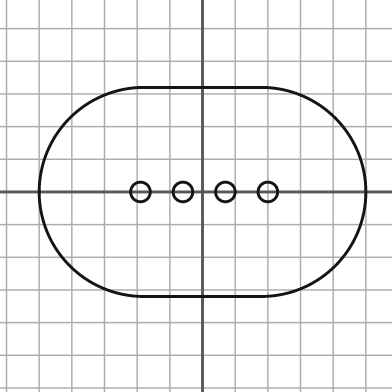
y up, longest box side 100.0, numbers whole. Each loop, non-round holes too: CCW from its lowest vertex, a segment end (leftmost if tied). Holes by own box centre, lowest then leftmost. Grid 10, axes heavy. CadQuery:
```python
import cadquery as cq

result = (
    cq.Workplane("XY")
    .moveTo(-18.0, -32.0)
    .lineTo(18.0, -32.0)
    .threePointArc((50.0, 0.0), (18.0, 32.0))
    .lineTo(-18.0, 32.0)
    .threePointArc((-50.0, 0.0), (-18.0, -32.0))
    .close()
    .moveTo(-19.0, 0.0)
    .circle(3.0)
    .moveTo(-6.0, 0.0)
    .circle(3.0)
    .moveTo(7.0, 0.0)
    .circle(3.0)
    .moveTo(20.0, 0.0)
    .circle(3.0)
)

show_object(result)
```